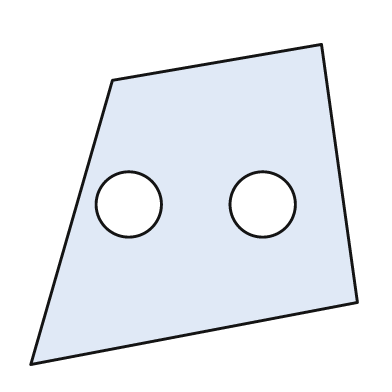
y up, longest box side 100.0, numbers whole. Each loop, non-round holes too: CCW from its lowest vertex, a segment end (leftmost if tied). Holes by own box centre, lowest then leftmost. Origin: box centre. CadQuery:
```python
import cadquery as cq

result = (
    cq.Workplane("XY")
    .moveTo(-50.0, -49.0)
    .lineTo(50.0, -30.0)
    .lineTo(39.0, 49.0)
    .lineTo(-25.0, 38.0)
    .close()
    .moveTo(-20.0, 0.0)
    .circle(10.0)
    .moveTo(21.0, 0.0)
    .circle(10.0)
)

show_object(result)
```